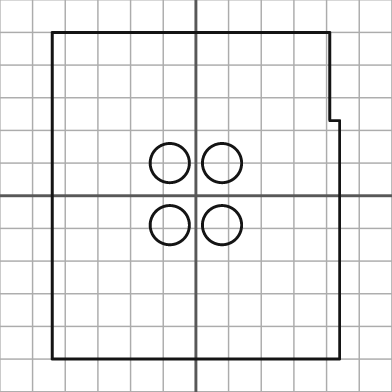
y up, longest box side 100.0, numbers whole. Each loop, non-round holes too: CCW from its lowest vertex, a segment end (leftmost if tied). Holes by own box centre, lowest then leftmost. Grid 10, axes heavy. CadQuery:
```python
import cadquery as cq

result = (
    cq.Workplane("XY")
    .moveTo(-44.0, -50.0)
    .lineTo(44.0, -50.0)
    .lineTo(44.0, 23.0)
    .lineTo(41.0, 23.0)
    .lineTo(41.0, 50.0)
    .lineTo(-44.0, 50.0)
    .close()
    .moveTo(-8.0, -9.0)
    .circle(6.0)
    .moveTo(8.0, -9.0)
    .circle(6.0)
    .moveTo(-8.0, 10.0)
    .circle(6.0)
    .moveTo(8.0, 10.0)
    .circle(6.0)
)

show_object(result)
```